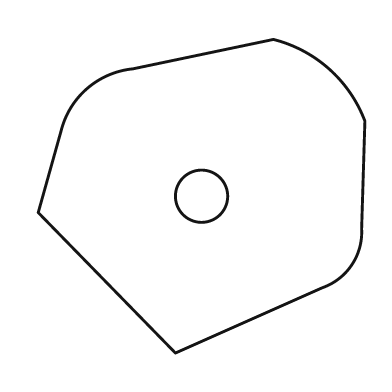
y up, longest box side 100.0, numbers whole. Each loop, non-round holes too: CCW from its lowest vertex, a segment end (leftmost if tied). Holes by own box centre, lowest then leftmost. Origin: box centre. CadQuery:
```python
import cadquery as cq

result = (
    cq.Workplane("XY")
    .moveTo(-8.0, -48.0)
    .lineTo(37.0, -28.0)
    .threePointArc((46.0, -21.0), (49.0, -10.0))
    .lineTo(50.0, 23.0)
    .threePointArc((39.0, 39.0), (22.0, 48.0))
    .lineTo(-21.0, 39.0)
    .threePointArc((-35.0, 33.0), (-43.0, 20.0))
    .lineTo(-50.0, -5.0)
    .close()
    .moveTo(0.0, 0.0)
    .circle(8.0)
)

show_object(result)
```